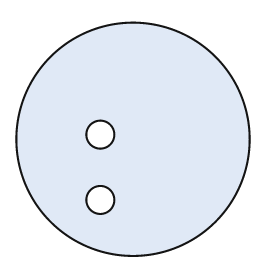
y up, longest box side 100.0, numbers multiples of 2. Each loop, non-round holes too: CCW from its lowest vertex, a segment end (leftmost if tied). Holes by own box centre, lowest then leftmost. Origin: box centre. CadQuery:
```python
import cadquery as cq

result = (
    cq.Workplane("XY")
    .moveTo(0.0, 0.0)
    .circle(50.0)
    .moveTo(-14.0, -26.0)
    .circle(6.0)
    .moveTo(-14.0, 2.0)
    .circle(6.0)
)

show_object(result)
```